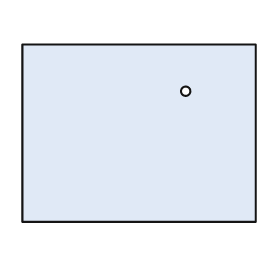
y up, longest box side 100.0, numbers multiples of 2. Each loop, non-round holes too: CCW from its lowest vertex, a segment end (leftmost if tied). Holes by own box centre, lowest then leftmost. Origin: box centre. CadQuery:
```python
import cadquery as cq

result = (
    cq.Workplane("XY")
    .moveTo(-50.0, -38.0)
    .lineTo(50.0, -38.0)
    .lineTo(50.0, 38.0)
    .lineTo(-50.0, 38.0)
    .close()
    .moveTo(20.0, 18.0)
    .circle(2.0)
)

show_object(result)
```